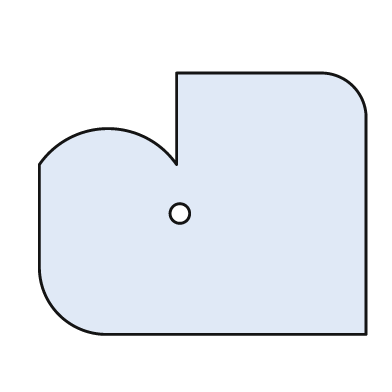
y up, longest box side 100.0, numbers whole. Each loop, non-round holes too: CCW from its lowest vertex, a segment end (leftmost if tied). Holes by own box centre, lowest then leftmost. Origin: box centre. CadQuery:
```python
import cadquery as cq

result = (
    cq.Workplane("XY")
    .moveTo(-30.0, -40.0)
    .lineTo(50.0, -40.0)
    .lineTo(50.0, 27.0)
    .threePointArc((46.0, 36.0), (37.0, 40.0))
    .lineTo(-8.0, 40.0)
    .lineTo(-8.0, 12.0)
    .threePointArc((-29.0, 23.0), (-50.0, 12.0))
    .lineTo(-50.0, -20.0)
    .threePointArc((-44.0, -34.0), (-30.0, -40.0))
    .close()
    .moveTo(-7.0, -3.0)
    .circle(3.0)
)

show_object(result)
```